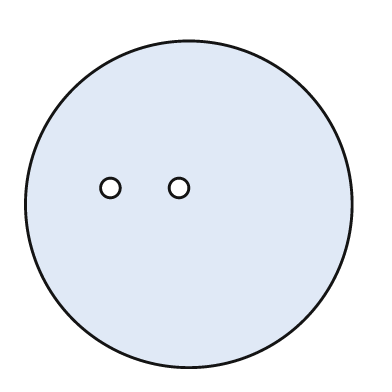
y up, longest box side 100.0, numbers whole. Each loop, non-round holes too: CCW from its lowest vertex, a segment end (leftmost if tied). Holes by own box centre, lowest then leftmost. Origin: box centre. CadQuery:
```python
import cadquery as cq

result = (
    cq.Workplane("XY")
    .moveTo(0.0, 0.0)
    .circle(50.0)
    .moveTo(-24.0, 5.0)
    .circle(3.0)
    .moveTo(-3.0, 5.0)
    .circle(3.0)
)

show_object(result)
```